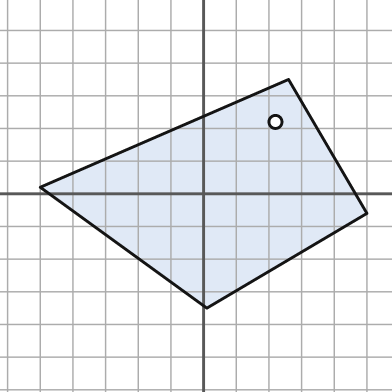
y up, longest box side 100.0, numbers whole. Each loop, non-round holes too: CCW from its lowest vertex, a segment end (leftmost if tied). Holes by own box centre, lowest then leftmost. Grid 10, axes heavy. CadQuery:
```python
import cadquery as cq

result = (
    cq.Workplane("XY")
    .moveTo(1.0, -35.0)
    .lineTo(50.0, -6.0)
    .lineTo(26.0, 35.0)
    .lineTo(-50.0, 2.0)
    .close()
    .moveTo(22.0, 22.0)
    .circle(2.0)
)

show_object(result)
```